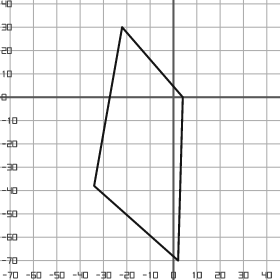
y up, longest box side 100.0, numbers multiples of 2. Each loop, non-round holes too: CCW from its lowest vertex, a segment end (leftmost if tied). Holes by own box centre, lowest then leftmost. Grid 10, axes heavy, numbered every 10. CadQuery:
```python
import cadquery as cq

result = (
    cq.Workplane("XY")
    .moveTo(2.0, -70.0)
    .lineTo(4.0, 0.0)
    .lineTo(-22.0, 30.0)
    .lineTo(-34.0, -38.0)
    .close()
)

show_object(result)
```